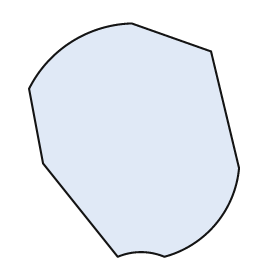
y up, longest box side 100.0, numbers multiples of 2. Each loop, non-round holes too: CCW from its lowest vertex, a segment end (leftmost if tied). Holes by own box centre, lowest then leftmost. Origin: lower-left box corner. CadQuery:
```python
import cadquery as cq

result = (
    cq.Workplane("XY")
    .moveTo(38.0, 0.0)
    .threePointArc((48.0, 2.0), (58.0, 0.0))
    .threePointArc((80.0, 14.0), (90.0, 38.0))
    .lineTo(78.0, 88.0)
    .lineTo(44.0, 100.0)
    .threePointArc((18.0, 92.0), (0.0, 72.0))
    .lineTo(6.0, 40.0)
    .close()
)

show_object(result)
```